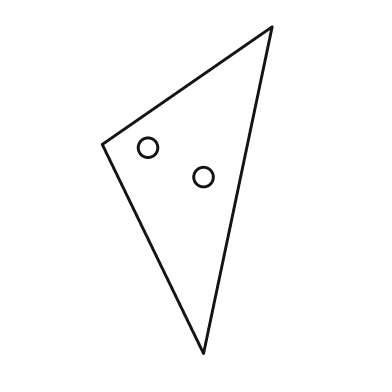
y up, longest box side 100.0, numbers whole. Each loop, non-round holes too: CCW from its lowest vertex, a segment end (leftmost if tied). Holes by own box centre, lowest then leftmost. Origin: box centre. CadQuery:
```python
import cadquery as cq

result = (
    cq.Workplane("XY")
    .moveTo(5.0, -50.0)
    .lineTo(26.0, 50.0)
    .lineTo(-26.0, 14.0)
    .close()
    .moveTo(5.0, 4.0)
    .circle(3.0)
    .moveTo(-12.0, 13.0)
    .circle(3.0)
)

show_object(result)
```